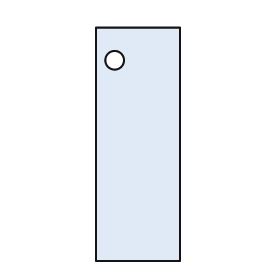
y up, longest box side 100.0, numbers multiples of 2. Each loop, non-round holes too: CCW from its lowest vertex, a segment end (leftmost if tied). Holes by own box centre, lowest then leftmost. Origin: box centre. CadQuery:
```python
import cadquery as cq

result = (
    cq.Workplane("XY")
    .moveTo(-18.0, -50.0)
    .lineTo(18.0, -50.0)
    .lineTo(18.0, 50.0)
    .lineTo(-18.0, 50.0)
    .close()
    .moveTo(-10.0, 36.0)
    .circle(4.0)
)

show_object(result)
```